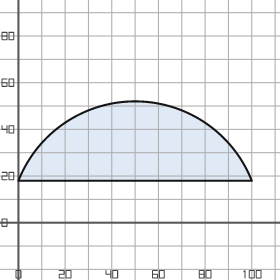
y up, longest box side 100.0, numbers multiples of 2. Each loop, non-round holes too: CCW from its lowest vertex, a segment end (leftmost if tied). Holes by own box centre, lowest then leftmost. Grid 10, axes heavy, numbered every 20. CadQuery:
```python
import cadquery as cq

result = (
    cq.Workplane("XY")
    .moveTo(0.0, 18.0)
    .lineTo(100.0, 18.0)
    .threePointArc((50.0, 52.0), (0.0, 18.0))
    .close()
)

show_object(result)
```